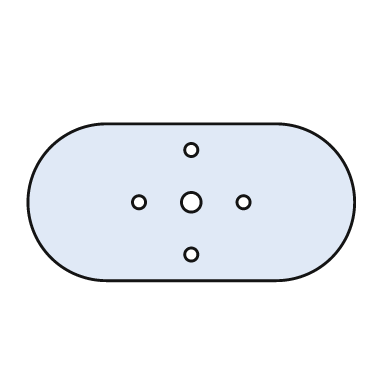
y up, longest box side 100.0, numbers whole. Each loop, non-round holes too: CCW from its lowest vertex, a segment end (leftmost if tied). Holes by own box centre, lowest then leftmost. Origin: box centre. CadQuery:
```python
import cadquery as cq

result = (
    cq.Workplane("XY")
    .moveTo(-26.0, -24.0)
    .lineTo(26.0, -24.0)
    .threePointArc((50.0, 0.0), (26.0, 24.0))
    .lineTo(-26.0, 24.0)
    .threePointArc((-50.0, 0.0), (-26.0, -24.0))
    .close()
    .moveTo(0.0, -16.0)
    .circle(2.0)
    .moveTo(-16.0, 0.0)
    .circle(2.0)
    .moveTo(0.0, 0.0)
    .circle(3.0)
    .moveTo(16.0, 0.0)
    .circle(2.0)
    .moveTo(0.0, 16.0)
    .circle(2.0)
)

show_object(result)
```